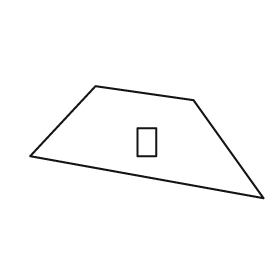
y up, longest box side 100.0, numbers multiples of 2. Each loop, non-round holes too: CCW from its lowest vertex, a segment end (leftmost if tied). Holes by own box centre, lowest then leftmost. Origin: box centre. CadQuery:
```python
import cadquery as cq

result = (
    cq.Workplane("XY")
    .moveTo(50.0, -24.0)
    .lineTo(20.0, 18.0)
    .lineTo(-22.0, 24.0)
    .lineTo(-50.0, -6.0)
    .close()
    .moveTo(-4.0, -6.0)
    .lineTo(4.0, -6.0)
    .lineTo(4.0, 6.0)
    .lineTo(-4.0, 6.0)
    .close()
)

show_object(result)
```